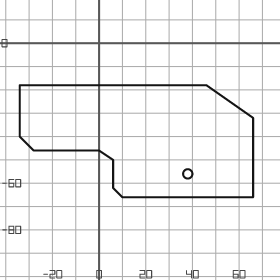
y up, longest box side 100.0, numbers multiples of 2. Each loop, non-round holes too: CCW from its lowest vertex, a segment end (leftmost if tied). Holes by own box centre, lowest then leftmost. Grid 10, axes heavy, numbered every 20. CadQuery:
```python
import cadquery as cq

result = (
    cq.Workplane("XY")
    .moveTo(10.0, -66.0)
    .lineTo(66.0, -66.0)
    .lineTo(66.0, -32.0)
    .lineTo(46.0, -18.0)
    .lineTo(-34.0, -18.0)
    .lineTo(-34.0, -40.0)
    .lineTo(-28.0, -46.0)
    .lineTo(0.0, -46.0)
    .lineTo(6.0, -50.0)
    .lineTo(6.0, -62.0)
    .close()
    .moveTo(38.0, -56.0)
    .circle(2.0)
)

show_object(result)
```